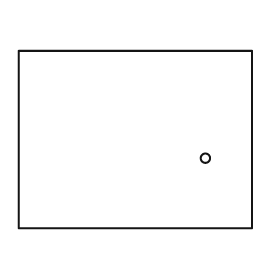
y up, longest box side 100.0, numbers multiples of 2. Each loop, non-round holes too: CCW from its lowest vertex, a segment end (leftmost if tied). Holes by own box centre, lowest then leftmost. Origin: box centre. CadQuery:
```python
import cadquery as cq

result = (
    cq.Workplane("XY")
    .moveTo(-50.0, -38.0)
    .lineTo(50.0, -38.0)
    .lineTo(50.0, 38.0)
    .lineTo(-50.0, 38.0)
    .close()
    .moveTo(30.0, -8.0)
    .circle(2.0)
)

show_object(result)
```